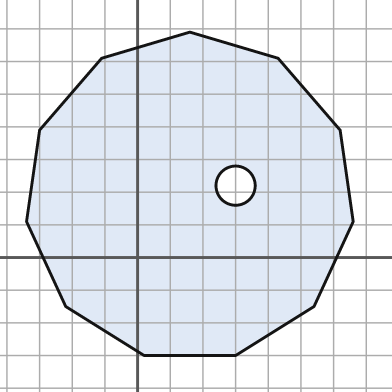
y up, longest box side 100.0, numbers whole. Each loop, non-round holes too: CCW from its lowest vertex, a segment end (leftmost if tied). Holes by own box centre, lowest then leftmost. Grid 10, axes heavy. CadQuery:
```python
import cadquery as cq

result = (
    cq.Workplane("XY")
    .moveTo(2.0, -30.0)
    .lineTo(30.0, -30.0)
    .lineTo(54.0, -15.0)
    .lineTo(66.0, 11.0)
    .lineTo(62.0, 39.0)
    .lineTo(43.0, 61.0)
    .lineTo(16.0, 69.0)
    .lineTo(-11.0, 61.0)
    .lineTo(-30.0, 39.0)
    .lineTo(-34.0, 11.0)
    .lineTo(-22.0, -15.0)
    .close()
    .moveTo(30.0, 22.0)
    .circle(6.0)
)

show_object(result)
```